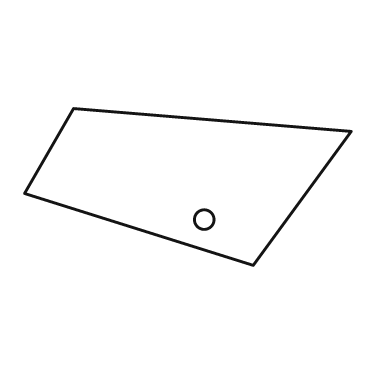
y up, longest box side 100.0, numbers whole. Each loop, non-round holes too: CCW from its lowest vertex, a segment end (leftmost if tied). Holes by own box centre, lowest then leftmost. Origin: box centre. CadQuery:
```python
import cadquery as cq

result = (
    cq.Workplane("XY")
    .moveTo(20.0, -24.0)
    .lineTo(50.0, 17.0)
    .lineTo(-35.0, 24.0)
    .lineTo(-50.0, -2.0)
    .close()
    .moveTo(5.0, -10.0)
    .circle(3.0)
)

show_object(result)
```